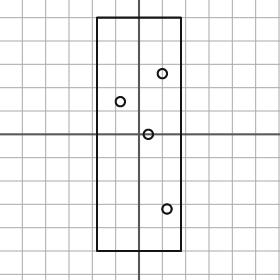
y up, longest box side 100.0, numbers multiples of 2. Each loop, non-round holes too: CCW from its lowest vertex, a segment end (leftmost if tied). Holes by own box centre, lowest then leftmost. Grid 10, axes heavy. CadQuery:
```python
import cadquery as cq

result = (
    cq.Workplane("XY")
    .moveTo(-18.0, -50.0)
    .lineTo(18.0, -50.0)
    .lineTo(18.0, 50.0)
    .lineTo(-18.0, 50.0)
    .close()
    .moveTo(12.0, -32.0)
    .circle(2.0)
    .moveTo(4.0, 0.0)
    .circle(2.0)
    .moveTo(-8.0, 14.0)
    .circle(2.0)
    .moveTo(10.0, 26.0)
    .circle(2.0)
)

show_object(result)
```